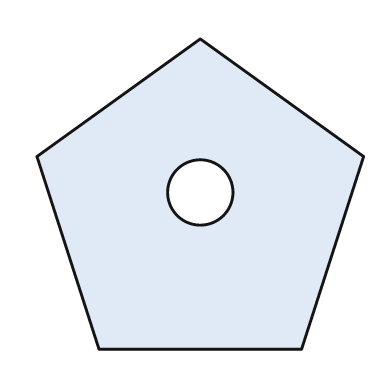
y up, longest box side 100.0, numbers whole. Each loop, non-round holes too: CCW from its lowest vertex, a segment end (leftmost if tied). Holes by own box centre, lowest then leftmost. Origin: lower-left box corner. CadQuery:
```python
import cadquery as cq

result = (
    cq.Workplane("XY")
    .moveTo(19.0, 0.0)
    .lineTo(81.0, 0.0)
    .lineTo(100.0, 59.0)
    .lineTo(50.0, 95.0)
    .lineTo(0.0, 59.0)
    .close()
    .moveTo(50.0, 48.0)
    .circle(10.0)
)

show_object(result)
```